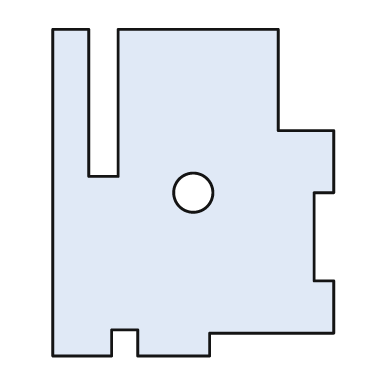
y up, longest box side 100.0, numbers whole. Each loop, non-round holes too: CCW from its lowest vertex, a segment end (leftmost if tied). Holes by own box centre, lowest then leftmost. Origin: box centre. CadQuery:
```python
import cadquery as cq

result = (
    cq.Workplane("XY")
    .moveTo(-43.0, -50.0)
    .lineTo(-25.0, -50.0)
    .lineTo(-25.0, -42.0)
    .lineTo(-17.0, -42.0)
    .lineTo(-17.0, -50.0)
    .lineTo(5.0, -50.0)
    .lineTo(5.0, -43.0)
    .lineTo(43.0, -43.0)
    .lineTo(43.0, -27.0)
    .lineTo(37.0, -27.0)
    .lineTo(37.0, 0.0)
    .lineTo(43.0, 0.0)
    .lineTo(43.0, 19.0)
    .lineTo(26.0, 19.0)
    .lineTo(26.0, 50.0)
    .lineTo(-23.0, 50.0)
    .lineTo(-23.0, 5.0)
    .lineTo(-32.0, 5.0)
    .lineTo(-32.0, 50.0)
    .lineTo(-43.0, 50.0)
    .close()
    .moveTo(0.0, 0.0)
    .circle(6.0)
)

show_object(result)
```